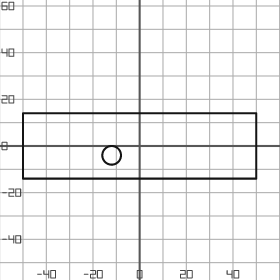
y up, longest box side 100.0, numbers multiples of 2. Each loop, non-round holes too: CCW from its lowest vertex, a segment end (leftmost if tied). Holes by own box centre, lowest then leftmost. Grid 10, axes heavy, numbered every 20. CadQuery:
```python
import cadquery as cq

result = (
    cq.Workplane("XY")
    .moveTo(-50.0, -14.0)
    .lineTo(50.0, -14.0)
    .lineTo(50.0, 14.0)
    .lineTo(-50.0, 14.0)
    .close()
    .moveTo(-12.0, -4.0)
    .circle(4.0)
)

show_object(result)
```